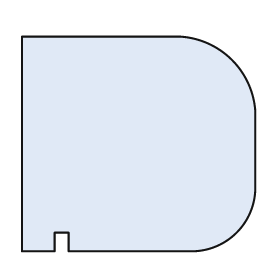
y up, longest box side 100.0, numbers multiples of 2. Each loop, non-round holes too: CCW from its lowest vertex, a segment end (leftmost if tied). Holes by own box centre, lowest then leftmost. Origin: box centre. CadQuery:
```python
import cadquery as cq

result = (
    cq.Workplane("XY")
    .moveTo(-50.0, -46.0)
    .lineTo(-36.0, -46.0)
    .lineTo(-36.0, -38.0)
    .lineTo(-30.0, -38.0)
    .lineTo(-30.0, -46.0)
    .lineTo(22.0, -46.0)
    .threePointArc((42.0, -38.0), (50.0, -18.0))
    .lineTo(50.0, 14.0)
    .threePointArc((40.0, 36.0), (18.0, 46.0))
    .lineTo(-50.0, 46.0)
    .close()
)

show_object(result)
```